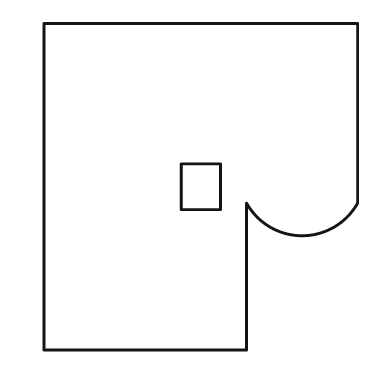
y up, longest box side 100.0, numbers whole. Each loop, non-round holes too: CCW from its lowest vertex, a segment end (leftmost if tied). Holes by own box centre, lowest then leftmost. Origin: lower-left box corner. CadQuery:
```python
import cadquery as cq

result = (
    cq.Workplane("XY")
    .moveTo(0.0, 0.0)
    .lineTo(62.0, 0.0)
    .lineTo(62.0, 45.0)
    .threePointArc((79.0, 35.0), (96.0, 45.0))
    .lineTo(96.0, 100.0)
    .lineTo(0.0, 100.0)
    .close()
    .moveTo(42.0, 43.0)
    .lineTo(54.0, 43.0)
    .lineTo(54.0, 57.0)
    .lineTo(42.0, 57.0)
    .close()
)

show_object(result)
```